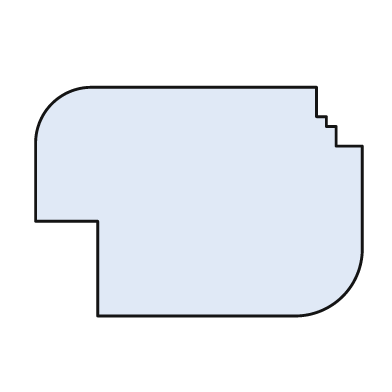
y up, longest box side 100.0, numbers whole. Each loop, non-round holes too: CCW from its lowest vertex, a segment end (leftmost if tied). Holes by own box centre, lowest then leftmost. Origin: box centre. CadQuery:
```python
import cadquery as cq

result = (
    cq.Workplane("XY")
    .moveTo(-31.0, -35.0)
    .lineTo(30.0, -35.0)
    .threePointArc((44.0, -29.0), (50.0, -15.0))
    .lineTo(50.0, 17.0)
    .lineTo(42.0, 17.0)
    .lineTo(42.0, 23.0)
    .lineTo(39.0, 23.0)
    .lineTo(39.0, 26.0)
    .lineTo(36.0, 26.0)
    .lineTo(36.0, 35.0)
    .lineTo(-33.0, 35.0)
    .threePointArc((-45.0, 30.0), (-50.0, 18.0))
    .lineTo(-50.0, -6.0)
    .lineTo(-31.0, -6.0)
    .close()
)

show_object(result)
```